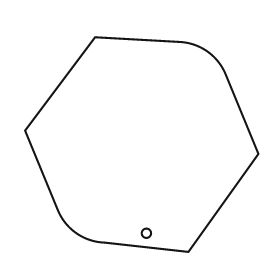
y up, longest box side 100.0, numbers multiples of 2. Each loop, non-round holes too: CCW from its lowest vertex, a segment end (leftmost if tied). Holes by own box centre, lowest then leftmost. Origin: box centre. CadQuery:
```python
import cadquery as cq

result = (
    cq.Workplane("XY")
    .moveTo(20.0, -46.0)
    .lineTo(50.0, -4.0)
    .lineTo(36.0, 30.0)
    .threePointArc((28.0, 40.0), (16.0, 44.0))
    .lineTo(-20.0, 46.0)
    .lineTo(-50.0, 6.0)
    .lineTo(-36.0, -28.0)
    .threePointArc((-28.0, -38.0), (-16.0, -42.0))
    .close()
    .moveTo(2.0, -38.0)
    .circle(2.0)
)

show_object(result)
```